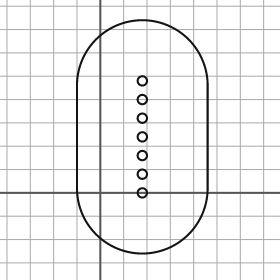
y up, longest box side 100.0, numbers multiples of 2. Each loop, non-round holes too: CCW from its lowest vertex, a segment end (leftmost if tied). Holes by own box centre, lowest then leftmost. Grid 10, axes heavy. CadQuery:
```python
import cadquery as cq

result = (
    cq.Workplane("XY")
    .moveTo(-10.0, 2.0)
    .threePointArc((18.0, -26.0), (46.0, 2.0))
    .lineTo(46.0, 46.0)
    .threePointArc((18.0, 74.0), (-10.0, 46.0))
    .close()
    .moveTo(18.0, 0.0)
    .circle(2.0)
    .moveTo(18.0, 8.0)
    .circle(2.0)
    .moveTo(18.0, 16.0)
    .circle(2.0)
    .moveTo(18.0, 24.0)
    .circle(2.0)
    .moveTo(18.0, 32.0)
    .circle(2.0)
    .moveTo(18.0, 40.0)
    .circle(2.0)
    .moveTo(18.0, 48.0)
    .circle(2.0)
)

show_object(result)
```